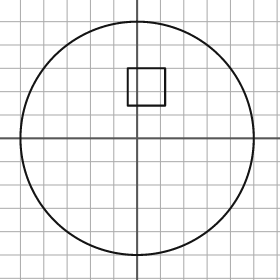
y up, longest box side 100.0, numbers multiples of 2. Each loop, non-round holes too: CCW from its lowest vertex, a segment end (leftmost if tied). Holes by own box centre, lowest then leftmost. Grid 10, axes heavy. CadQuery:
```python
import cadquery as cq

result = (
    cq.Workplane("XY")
    .moveTo(0.0, 0.0)
    .circle(50.0)
    .moveTo(-4.0, 14.0)
    .lineTo(12.0, 14.0)
    .lineTo(12.0, 30.0)
    .lineTo(-4.0, 30.0)
    .close()
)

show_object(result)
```